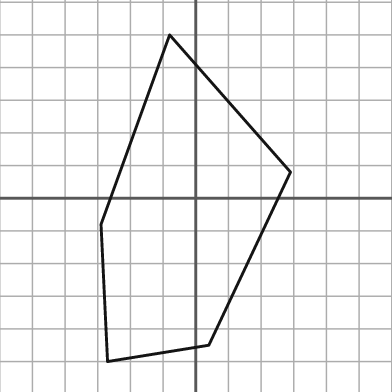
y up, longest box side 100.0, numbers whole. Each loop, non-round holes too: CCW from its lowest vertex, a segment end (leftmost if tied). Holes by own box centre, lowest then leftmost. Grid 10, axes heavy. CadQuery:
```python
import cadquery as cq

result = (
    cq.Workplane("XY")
    .moveTo(-27.0, -50.0)
    .lineTo(4.0, -45.0)
    .lineTo(29.0, 8.0)
    .lineTo(-8.0, 50.0)
    .lineTo(-29.0, -8.0)
    .close()
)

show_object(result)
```